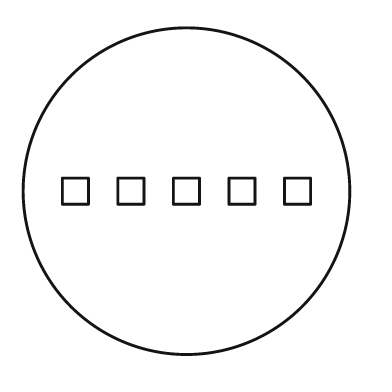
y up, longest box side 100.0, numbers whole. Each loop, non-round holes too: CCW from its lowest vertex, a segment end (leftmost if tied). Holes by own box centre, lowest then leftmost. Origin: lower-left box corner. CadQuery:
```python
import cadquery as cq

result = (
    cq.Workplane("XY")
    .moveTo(50.0, 50.0)
    .circle(50.0)
    .moveTo(12.0, 46.0)
    .lineTo(20.0, 46.0)
    .lineTo(20.0, 54.0)
    .lineTo(12.0, 54.0)
    .close()
    .moveTo(29.0, 46.0)
    .lineTo(37.0, 46.0)
    .lineTo(37.0, 54.0)
    .lineTo(29.0, 54.0)
    .close()
    .moveTo(46.0, 46.0)
    .lineTo(54.0, 46.0)
    .lineTo(54.0, 54.0)
    .lineTo(46.0, 54.0)
    .close()
    .moveTo(63.0, 46.0)
    .lineTo(71.0, 46.0)
    .lineTo(71.0, 54.0)
    .lineTo(63.0, 54.0)
    .close()
    .moveTo(80.0, 46.0)
    .lineTo(88.0, 46.0)
    .lineTo(88.0, 54.0)
    .lineTo(80.0, 54.0)
    .close()
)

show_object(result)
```